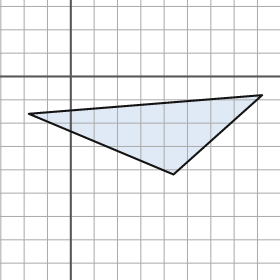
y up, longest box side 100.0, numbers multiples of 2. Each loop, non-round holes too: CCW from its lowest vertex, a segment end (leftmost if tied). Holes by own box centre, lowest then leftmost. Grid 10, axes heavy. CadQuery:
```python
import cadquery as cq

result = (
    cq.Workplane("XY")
    .moveTo(44.0, -42.0)
    .lineTo(82.0, -8.0)
    .lineTo(-18.0, -16.0)
    .close()
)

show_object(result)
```